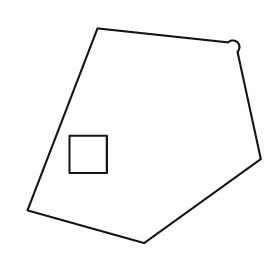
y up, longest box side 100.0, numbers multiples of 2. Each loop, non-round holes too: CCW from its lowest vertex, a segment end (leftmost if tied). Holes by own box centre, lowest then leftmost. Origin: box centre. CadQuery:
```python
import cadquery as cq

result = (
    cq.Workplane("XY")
    .moveTo(0.0, -46.0)
    .lineTo(50.0, -10.0)
    .lineTo(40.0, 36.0)
    .threePointArc((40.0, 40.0), (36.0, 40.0))
    .lineTo(-20.0, 46.0)
    .lineTo(-50.0, -32.0)
    .close()
    .moveTo(-32.0, -16.0)
    .lineTo(-16.0, -16.0)
    .lineTo(-16.0, 0.0)
    .lineTo(-32.0, 0.0)
    .close()
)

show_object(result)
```